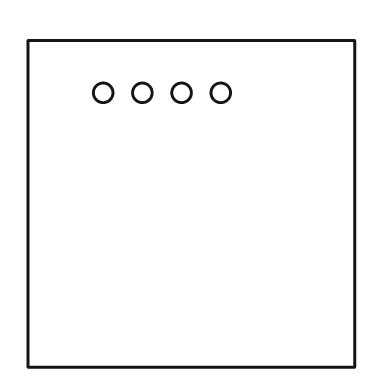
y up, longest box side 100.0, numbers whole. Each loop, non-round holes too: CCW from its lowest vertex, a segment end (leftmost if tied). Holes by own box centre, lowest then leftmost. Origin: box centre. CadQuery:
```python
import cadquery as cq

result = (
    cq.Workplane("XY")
    .moveTo(-50.0, -50.0)
    .lineTo(50.0, -50.0)
    .lineTo(50.0, 50.0)
    .lineTo(-50.0, 50.0)
    .close()
    .moveTo(-27.0, 34.0)
    .circle(3.0)
    .moveTo(-15.0, 34.0)
    .circle(3.0)
    .moveTo(-3.0, 34.0)
    .circle(3.0)
    .moveTo(9.0, 34.0)
    .circle(3.0)
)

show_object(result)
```